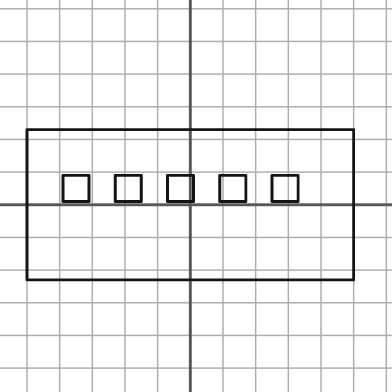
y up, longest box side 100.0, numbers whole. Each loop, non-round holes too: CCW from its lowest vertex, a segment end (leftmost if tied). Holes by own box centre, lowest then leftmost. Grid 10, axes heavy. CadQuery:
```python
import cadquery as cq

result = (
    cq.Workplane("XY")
    .moveTo(-50.0, -23.0)
    .lineTo(50.0, -23.0)
    .lineTo(50.0, 23.0)
    .lineTo(-50.0, 23.0)
    .close()
    .moveTo(-39.0, 1.0)
    .lineTo(-31.0, 1.0)
    .lineTo(-31.0, 9.0)
    .lineTo(-39.0, 9.0)
    .close()
    .moveTo(-23.0, 1.0)
    .lineTo(-15.0, 1.0)
    .lineTo(-15.0, 9.0)
    .lineTo(-23.0, 9.0)
    .close()
    .moveTo(-7.0, 1.0)
    .lineTo(1.0, 1.0)
    .lineTo(1.0, 9.0)
    .lineTo(-7.0, 9.0)
    .close()
    .moveTo(9.0, 1.0)
    .lineTo(17.0, 1.0)
    .lineTo(17.0, 9.0)
    .lineTo(9.0, 9.0)
    .close()
    .moveTo(25.0, 1.0)
    .lineTo(33.0, 1.0)
    .lineTo(33.0, 9.0)
    .lineTo(25.0, 9.0)
    .close()
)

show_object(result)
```